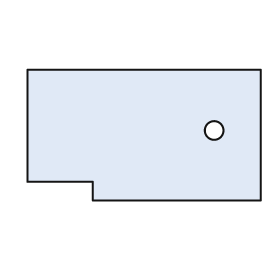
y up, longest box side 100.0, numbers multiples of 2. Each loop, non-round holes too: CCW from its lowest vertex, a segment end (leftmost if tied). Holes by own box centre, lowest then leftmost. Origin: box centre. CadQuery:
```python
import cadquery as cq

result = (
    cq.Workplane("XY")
    .moveTo(-22.0, -28.0)
    .lineTo(50.0, -28.0)
    .lineTo(50.0, 28.0)
    .lineTo(-50.0, 28.0)
    .lineTo(-50.0, -20.0)
    .lineTo(-22.0, -20.0)
    .close()
    .moveTo(30.0, 2.0)
    .circle(4.0)
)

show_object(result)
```